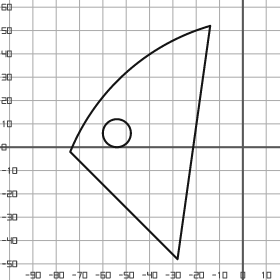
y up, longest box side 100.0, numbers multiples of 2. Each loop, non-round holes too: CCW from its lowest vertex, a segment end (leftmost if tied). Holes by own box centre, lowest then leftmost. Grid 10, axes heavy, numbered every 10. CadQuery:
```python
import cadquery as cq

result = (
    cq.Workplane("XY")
    .moveTo(-28.0, -48.0)
    .lineTo(-14.0, 52.0)
    .threePointArc((-50.0, 32.0), (-74.0, -2.0))
    .close()
    .moveTo(-54.0, 6.0)
    .circle(6.0)
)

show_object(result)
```